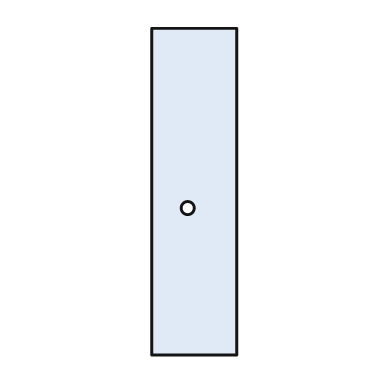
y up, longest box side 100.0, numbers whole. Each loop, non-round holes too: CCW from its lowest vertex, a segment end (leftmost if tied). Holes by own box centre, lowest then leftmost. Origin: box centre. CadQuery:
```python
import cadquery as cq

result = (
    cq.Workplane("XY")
    .moveTo(-13.0, -50.0)
    .lineTo(13.0, -50.0)
    .lineTo(13.0, 50.0)
    .lineTo(-13.0, 50.0)
    .close()
    .moveTo(-2.0, -5.0)
    .circle(2.0)
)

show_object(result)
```